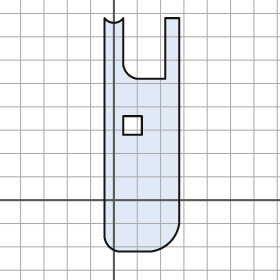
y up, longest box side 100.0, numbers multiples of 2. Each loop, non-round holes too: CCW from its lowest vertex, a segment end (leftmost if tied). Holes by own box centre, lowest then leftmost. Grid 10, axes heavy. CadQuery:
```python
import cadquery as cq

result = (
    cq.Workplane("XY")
    .moveTo(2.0, -22.0)
    .lineTo(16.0, -22.0)
    .threePointArc((24.0, -18.0), (28.0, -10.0))
    .lineTo(28.0, 78.0)
    .lineTo(22.0, 78.0)
    .lineTo(22.0, 52.0)
    .lineTo(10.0, 52.0)
    .threePointArc((6.0, 54.0), (4.0, 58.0))
    .lineTo(4.0, 78.0)
    .threePointArc((0.0, 76.0), (-4.0, 78.0))
    .lineTo(-4.0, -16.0)
    .threePointArc((-2.0, -20.0), (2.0, -22.0))
    .close()
    .moveTo(4.0, 28.0)
    .lineTo(12.0, 28.0)
    .lineTo(12.0, 36.0)
    .lineTo(4.0, 36.0)
    .close()
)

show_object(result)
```